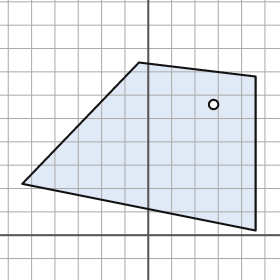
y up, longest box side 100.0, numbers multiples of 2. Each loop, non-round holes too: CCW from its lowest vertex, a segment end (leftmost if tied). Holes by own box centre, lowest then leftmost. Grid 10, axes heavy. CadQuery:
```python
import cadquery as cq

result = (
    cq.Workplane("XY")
    .moveTo(46.0, 2.0)
    .lineTo(46.0, 68.0)
    .lineTo(-4.0, 74.0)
    .lineTo(-54.0, 22.0)
    .close()
    .moveTo(28.0, 56.0)
    .circle(2.0)
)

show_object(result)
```